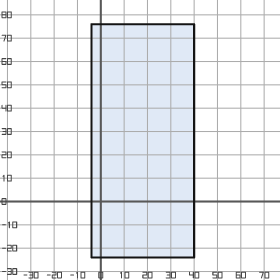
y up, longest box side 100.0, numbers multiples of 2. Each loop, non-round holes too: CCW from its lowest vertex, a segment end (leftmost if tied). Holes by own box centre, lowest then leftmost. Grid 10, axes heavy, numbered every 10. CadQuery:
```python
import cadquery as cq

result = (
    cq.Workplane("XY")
    .moveTo(-4.0, -24.0)
    .lineTo(40.0, -24.0)
    .lineTo(40.0, 76.0)
    .lineTo(-4.0, 76.0)
    .close()
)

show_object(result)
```